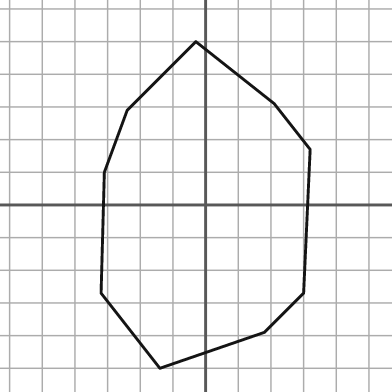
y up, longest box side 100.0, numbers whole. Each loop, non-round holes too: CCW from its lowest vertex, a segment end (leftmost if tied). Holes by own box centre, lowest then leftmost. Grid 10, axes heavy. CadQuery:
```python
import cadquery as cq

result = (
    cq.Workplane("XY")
    .moveTo(-14.0, -50.0)
    .lineTo(18.0, -39.0)
    .lineTo(30.0, -27.0)
    .lineTo(32.0, 17.0)
    .lineTo(21.0, 31.0)
    .lineTo(-3.0, 50.0)
    .lineTo(-24.0, 29.0)
    .lineTo(-31.0, 10.0)
    .lineTo(-32.0, -27.0)
    .close()
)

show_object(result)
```